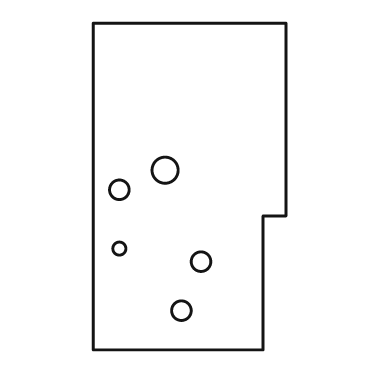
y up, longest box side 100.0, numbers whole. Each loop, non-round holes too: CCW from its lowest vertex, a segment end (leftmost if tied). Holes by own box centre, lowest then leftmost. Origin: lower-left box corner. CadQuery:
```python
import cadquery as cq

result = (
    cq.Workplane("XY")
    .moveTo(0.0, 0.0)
    .lineTo(52.0, 0.0)
    .lineTo(52.0, 41.0)
    .lineTo(59.0, 41.0)
    .lineTo(59.0, 100.0)
    .lineTo(0.0, 100.0)
    .close()
    .moveTo(27.0, 12.0)
    .circle(3.0)
    .moveTo(33.0, 27.0)
    .circle(3.0)
    .moveTo(8.0, 31.0)
    .circle(2.0)
    .moveTo(8.0, 49.0)
    .circle(3.0)
    .moveTo(22.0, 55.0)
    .circle(4.0)
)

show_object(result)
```